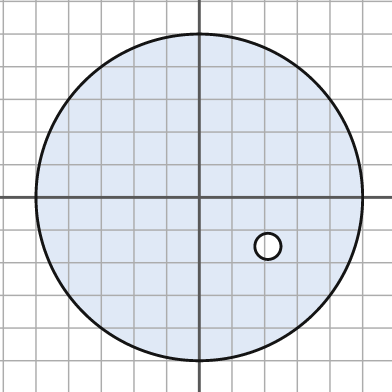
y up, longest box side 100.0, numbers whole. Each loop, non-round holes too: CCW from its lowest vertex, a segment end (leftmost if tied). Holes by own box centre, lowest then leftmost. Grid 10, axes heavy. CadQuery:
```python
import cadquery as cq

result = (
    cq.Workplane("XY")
    .moveTo(0.0, 0.0)
    .circle(50.0)
    .moveTo(21.0, -15.0)
    .circle(4.0)
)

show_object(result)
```